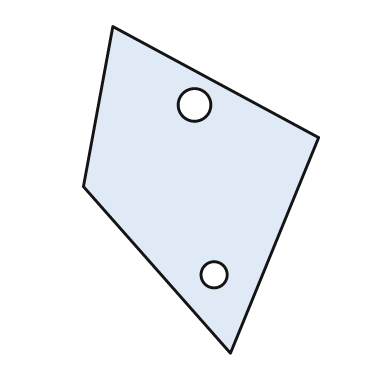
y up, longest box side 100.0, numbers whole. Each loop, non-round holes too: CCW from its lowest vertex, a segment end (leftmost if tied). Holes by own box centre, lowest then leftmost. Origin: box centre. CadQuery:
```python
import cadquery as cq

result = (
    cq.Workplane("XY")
    .moveTo(9.0, -50.0)
    .lineTo(36.0, 16.0)
    .lineTo(-27.0, 50.0)
    .lineTo(-36.0, 1.0)
    .close()
    .moveTo(4.0, -26.0)
    .circle(4.0)
    .moveTo(-2.0, 26.0)
    .circle(5.0)
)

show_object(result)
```